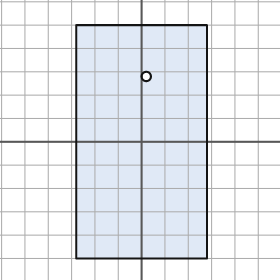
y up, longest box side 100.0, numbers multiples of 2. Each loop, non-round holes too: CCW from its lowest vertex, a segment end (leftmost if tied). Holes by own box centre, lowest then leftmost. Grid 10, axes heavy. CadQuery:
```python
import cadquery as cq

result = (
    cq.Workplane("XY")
    .moveTo(-28.0, -50.0)
    .lineTo(28.0, -50.0)
    .lineTo(28.0, 50.0)
    .lineTo(-28.0, 50.0)
    .close()
    .moveTo(2.0, 28.0)
    .circle(2.0)
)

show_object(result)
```